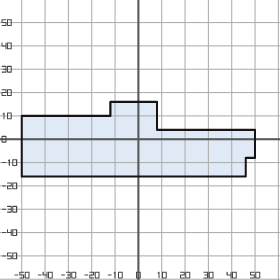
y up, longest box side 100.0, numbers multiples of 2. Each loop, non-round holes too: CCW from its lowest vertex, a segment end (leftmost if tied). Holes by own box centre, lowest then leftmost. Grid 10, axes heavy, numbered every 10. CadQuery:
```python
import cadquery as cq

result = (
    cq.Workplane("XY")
    .moveTo(-50.0, -16.0)
    .lineTo(46.0, -16.0)
    .lineTo(46.0, -8.0)
    .lineTo(50.0, -8.0)
    .lineTo(50.0, 4.0)
    .lineTo(8.0, 4.0)
    .lineTo(8.0, 16.0)
    .lineTo(-12.0, 16.0)
    .lineTo(-12.0, 10.0)
    .lineTo(-50.0, 10.0)
    .close()
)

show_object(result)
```